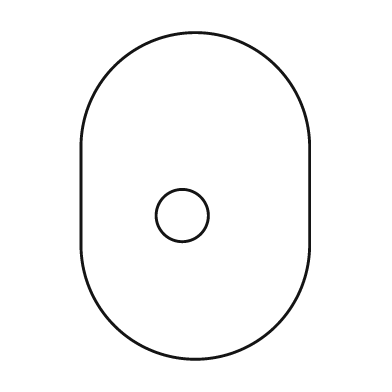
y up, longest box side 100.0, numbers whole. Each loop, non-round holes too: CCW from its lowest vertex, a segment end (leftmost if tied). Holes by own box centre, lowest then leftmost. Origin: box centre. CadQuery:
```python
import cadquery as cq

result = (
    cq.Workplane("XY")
    .moveTo(-35.0, -15.0)
    .threePointArc((0.0, -50.0), (35.0, -15.0))
    .lineTo(35.0, 15.0)
    .threePointArc((0.0, 50.0), (-35.0, 15.0))
    .close()
    .moveTo(-4.0, -6.0)
    .circle(8.0)
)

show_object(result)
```